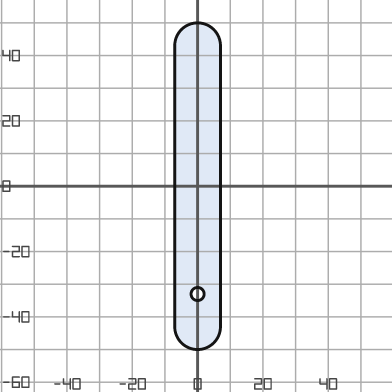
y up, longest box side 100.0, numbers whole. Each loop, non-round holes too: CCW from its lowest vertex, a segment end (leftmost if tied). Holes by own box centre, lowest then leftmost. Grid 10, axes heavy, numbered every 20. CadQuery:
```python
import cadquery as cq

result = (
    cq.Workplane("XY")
    .moveTo(-7.0, -43.0)
    .threePointArc((0.0, -50.0), (7.0, -43.0))
    .lineTo(7.0, 43.0)
    .threePointArc((0.0, 50.0), (-7.0, 43.0))
    .close()
    .moveTo(0.0, -33.0)
    .circle(2.0)
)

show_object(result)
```